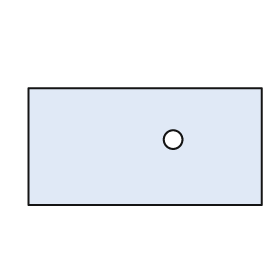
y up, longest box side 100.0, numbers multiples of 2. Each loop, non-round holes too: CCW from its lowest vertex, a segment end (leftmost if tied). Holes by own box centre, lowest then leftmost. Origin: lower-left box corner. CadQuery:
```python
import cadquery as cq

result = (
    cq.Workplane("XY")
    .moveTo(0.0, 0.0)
    .lineTo(100.0, 0.0)
    .lineTo(100.0, 50.0)
    .lineTo(0.0, 50.0)
    .close()
    .moveTo(62.0, 28.0)
    .circle(4.0)
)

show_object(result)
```